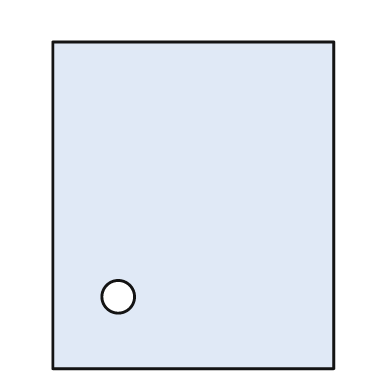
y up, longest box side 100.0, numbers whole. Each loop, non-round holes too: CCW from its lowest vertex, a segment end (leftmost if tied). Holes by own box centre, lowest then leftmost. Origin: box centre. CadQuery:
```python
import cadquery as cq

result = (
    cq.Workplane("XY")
    .moveTo(-43.0, -50.0)
    .lineTo(43.0, -50.0)
    .lineTo(43.0, 50.0)
    .lineTo(-43.0, 50.0)
    .close()
    .moveTo(-23.0, -28.0)
    .circle(5.0)
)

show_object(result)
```